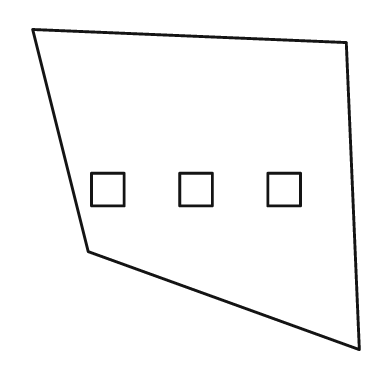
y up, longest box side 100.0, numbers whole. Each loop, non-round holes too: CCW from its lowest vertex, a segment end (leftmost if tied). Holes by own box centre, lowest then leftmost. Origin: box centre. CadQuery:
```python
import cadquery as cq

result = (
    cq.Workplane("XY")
    .moveTo(50.0, -49.0)
    .lineTo(46.0, 45.0)
    .lineTo(-50.0, 49.0)
    .lineTo(-33.0, -19.0)
    .close()
    .moveTo(-32.0, -5.0)
    .lineTo(-22.0, -5.0)
    .lineTo(-22.0, 5.0)
    .lineTo(-32.0, 5.0)
    .close()
    .moveTo(-5.0, -5.0)
    .lineTo(5.0, -5.0)
    .lineTo(5.0, 5.0)
    .lineTo(-5.0, 5.0)
    .close()
    .moveTo(22.0, -5.0)
    .lineTo(32.0, -5.0)
    .lineTo(32.0, 5.0)
    .lineTo(22.0, 5.0)
    .close()
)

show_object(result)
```